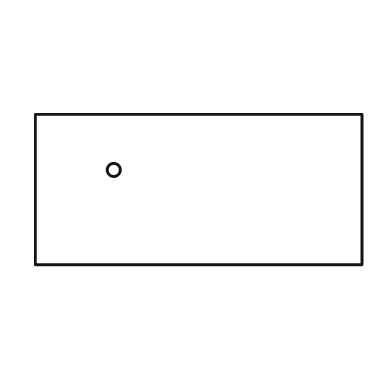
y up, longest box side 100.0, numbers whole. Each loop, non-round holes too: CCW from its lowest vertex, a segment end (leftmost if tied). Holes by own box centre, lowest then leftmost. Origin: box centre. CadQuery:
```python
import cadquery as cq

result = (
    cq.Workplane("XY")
    .moveTo(-50.0, -23.0)
    .lineTo(50.0, -23.0)
    .lineTo(50.0, 23.0)
    .lineTo(-50.0, 23.0)
    .close()
    .moveTo(-26.0, 6.0)
    .circle(2.0)
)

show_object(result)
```